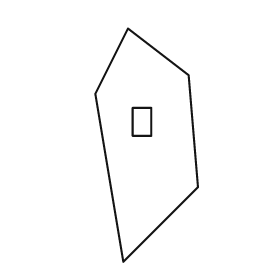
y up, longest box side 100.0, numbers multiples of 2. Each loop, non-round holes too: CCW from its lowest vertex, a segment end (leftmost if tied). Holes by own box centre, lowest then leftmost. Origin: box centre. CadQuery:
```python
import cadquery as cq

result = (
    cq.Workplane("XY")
    .moveTo(-10.0, -50.0)
    .lineTo(22.0, -18.0)
    .lineTo(18.0, 30.0)
    .lineTo(-8.0, 50.0)
    .lineTo(-22.0, 22.0)
    .close()
    .moveTo(-6.0, 4.0)
    .lineTo(2.0, 4.0)
    .lineTo(2.0, 16.0)
    .lineTo(-6.0, 16.0)
    .close()
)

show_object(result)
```